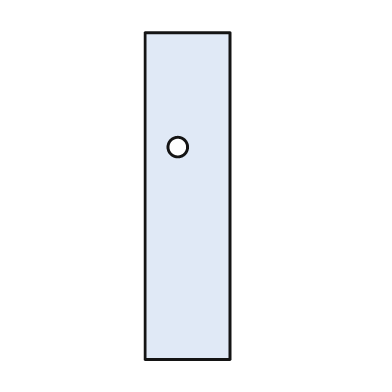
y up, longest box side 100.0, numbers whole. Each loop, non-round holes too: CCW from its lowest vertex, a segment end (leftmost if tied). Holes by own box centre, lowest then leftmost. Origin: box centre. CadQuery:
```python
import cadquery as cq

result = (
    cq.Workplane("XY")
    .moveTo(-13.0, -50.0)
    .lineTo(13.0, -50.0)
    .lineTo(13.0, 50.0)
    .lineTo(-13.0, 50.0)
    .close()
    .moveTo(-3.0, 15.0)
    .circle(3.0)
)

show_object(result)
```